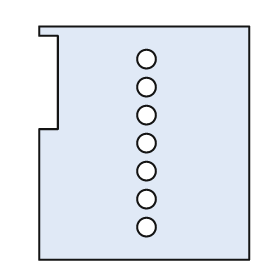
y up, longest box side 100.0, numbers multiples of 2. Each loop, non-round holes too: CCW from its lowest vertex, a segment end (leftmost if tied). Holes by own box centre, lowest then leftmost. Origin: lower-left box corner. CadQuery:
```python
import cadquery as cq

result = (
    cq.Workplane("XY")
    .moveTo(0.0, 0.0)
    .lineTo(90.0, 0.0)
    .lineTo(90.0, 100.0)
    .lineTo(0.0, 100.0)
    .lineTo(0.0, 96.0)
    .lineTo(8.0, 96.0)
    .lineTo(8.0, 56.0)
    .lineTo(0.0, 56.0)
    .close()
    .moveTo(46.0, 14.0)
    .circle(4.0)
    .moveTo(46.0, 26.0)
    .circle(4.0)
    .moveTo(46.0, 38.0)
    .circle(4.0)
    .moveTo(46.0, 50.0)
    .circle(4.0)
    .moveTo(46.0, 62.0)
    .circle(4.0)
    .moveTo(46.0, 74.0)
    .circle(4.0)
    .moveTo(46.0, 86.0)
    .circle(4.0)
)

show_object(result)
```